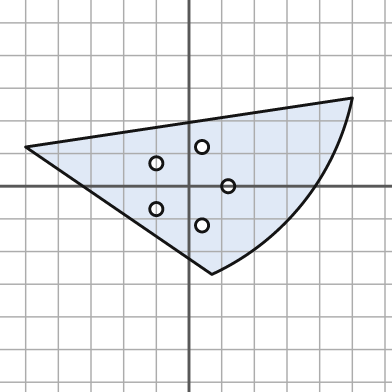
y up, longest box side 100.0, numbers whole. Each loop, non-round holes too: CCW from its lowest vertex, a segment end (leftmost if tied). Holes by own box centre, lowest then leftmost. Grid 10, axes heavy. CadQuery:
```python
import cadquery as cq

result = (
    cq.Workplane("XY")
    .moveTo(7.0, -27.0)
    .threePointArc((35.0, -5.0), (50.0, 27.0))
    .lineTo(-50.0, 12.0)
    .close()
    .moveTo(4.0, -12.0)
    .circle(2.0)
    .moveTo(-10.0, -7.0)
    .circle(2.0)
    .moveTo(12.0, 0.0)
    .circle(2.0)
    .moveTo(-10.0, 7.0)
    .circle(2.0)
    .moveTo(4.0, 12.0)
    .circle(2.0)
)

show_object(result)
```